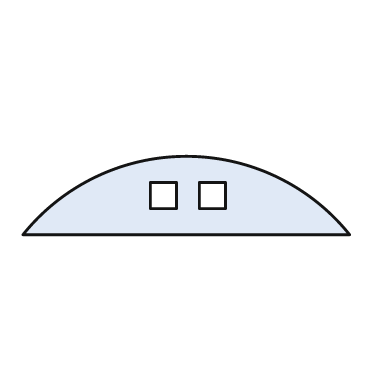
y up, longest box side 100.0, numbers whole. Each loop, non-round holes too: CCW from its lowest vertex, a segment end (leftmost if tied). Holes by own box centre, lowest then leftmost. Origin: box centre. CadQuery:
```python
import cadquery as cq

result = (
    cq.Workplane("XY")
    .moveTo(-50.0, -12.0)
    .lineTo(50.0, -12.0)
    .threePointArc((0.0, 12.0), (-50.0, -12.0))
    .close()
    .moveTo(-11.0, -4.0)
    .lineTo(-3.0, -4.0)
    .lineTo(-3.0, 4.0)
    .lineTo(-11.0, 4.0)
    .close()
    .moveTo(4.0, -4.0)
    .lineTo(12.0, -4.0)
    .lineTo(12.0, 4.0)
    .lineTo(4.0, 4.0)
    .close()
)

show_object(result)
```